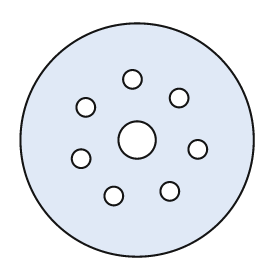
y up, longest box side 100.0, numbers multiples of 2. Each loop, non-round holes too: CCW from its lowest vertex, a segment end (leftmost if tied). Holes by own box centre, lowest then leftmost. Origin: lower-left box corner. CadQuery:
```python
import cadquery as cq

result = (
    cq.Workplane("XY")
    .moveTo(50.0, 50.0)
    .circle(50.0)
    .moveTo(40.0, 26.0)
    .circle(4.0)
    .moveTo(64.0, 28.0)
    .circle(4.0)
    .moveTo(26.0, 42.0)
    .circle(4.0)
    .moveTo(76.0, 46.0)
    .circle(4.0)
    .moveTo(50.0, 50.0)
    .circle(8.0)
    .moveTo(28.0, 64.0)
    .circle(4.0)
    .moveTo(68.0, 68.0)
    .circle(4.0)
    .moveTo(48.0, 76.0)
    .circle(4.0)
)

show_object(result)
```